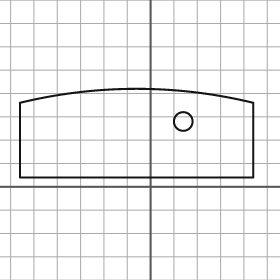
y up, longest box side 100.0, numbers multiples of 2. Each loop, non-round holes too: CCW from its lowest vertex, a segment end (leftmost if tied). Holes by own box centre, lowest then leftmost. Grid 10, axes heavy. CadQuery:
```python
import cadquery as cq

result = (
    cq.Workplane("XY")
    .moveTo(-56.0, 4.0)
    .lineTo(44.0, 4.0)
    .lineTo(44.0, 36.0)
    .threePointArc((-6.0, 42.0), (-56.0, 36.0))
    .close()
    .moveTo(14.0, 28.0)
    .circle(4.0)
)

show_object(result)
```